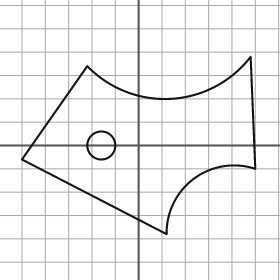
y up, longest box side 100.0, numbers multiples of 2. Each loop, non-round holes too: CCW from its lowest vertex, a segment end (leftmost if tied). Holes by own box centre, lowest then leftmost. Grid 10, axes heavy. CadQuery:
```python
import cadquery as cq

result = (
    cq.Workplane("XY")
    .moveTo(12.0, -38.0)
    .threePointArc((24.0, -14.0), (50.0, -10.0))
    .lineTo(48.0, 38.0)
    .threePointArc((14.0, 20.0), (-22.0, 34.0))
    .lineTo(-50.0, -6.0)
    .close()
    .moveTo(-16.0, 0.0)
    .circle(6.0)
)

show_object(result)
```